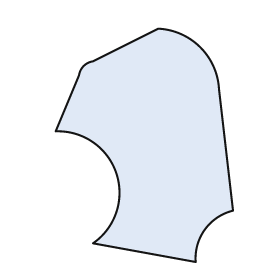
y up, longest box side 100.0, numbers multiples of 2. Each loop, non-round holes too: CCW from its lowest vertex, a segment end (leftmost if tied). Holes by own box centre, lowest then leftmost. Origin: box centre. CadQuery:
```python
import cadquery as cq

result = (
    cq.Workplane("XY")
    .moveTo(22.0, -50.0)
    .threePointArc((26.0, -36.0), (38.0, -28.0))
    .lineTo(32.0, 24.0)
    .threePointArc((24.0, 42.0), (6.0, 50.0))
    .lineTo(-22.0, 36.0)
    .threePointArc((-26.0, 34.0), (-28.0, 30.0))
    .lineTo(-38.0, 6.0)
    .threePointArc((-12.0, -12.0), (-22.0, -42.0))
    .close()
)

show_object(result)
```